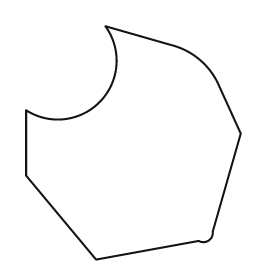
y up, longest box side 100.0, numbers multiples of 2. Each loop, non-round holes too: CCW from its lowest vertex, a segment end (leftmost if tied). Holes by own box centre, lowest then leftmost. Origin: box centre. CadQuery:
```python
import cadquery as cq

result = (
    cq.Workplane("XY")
    .moveTo(-16.0, -50.0)
    .lineTo(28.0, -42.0)
    .threePointArc((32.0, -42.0), (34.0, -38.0))
    .lineTo(46.0, 4.0)
    .lineTo(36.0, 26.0)
    .threePointArc((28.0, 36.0), (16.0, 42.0))
    .lineTo(-12.0, 50.0)
    .threePointArc((-14.0, 18.0), (-46.0, 14.0))
    .lineTo(-46.0, -14.0)
    .close()
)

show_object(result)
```